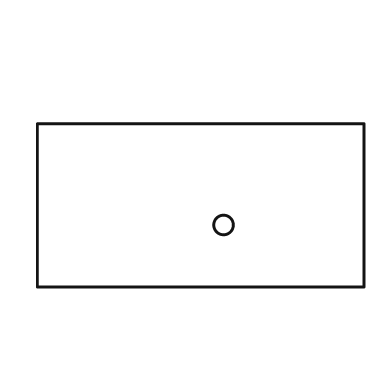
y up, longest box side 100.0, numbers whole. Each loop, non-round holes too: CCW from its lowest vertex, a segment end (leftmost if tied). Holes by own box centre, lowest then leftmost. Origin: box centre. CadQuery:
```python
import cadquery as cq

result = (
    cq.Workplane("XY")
    .moveTo(-50.0, -25.0)
    .lineTo(50.0, -25.0)
    .lineTo(50.0, 25.0)
    .lineTo(-50.0, 25.0)
    .close()
    .moveTo(7.0, -6.0)
    .circle(3.0)
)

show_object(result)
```